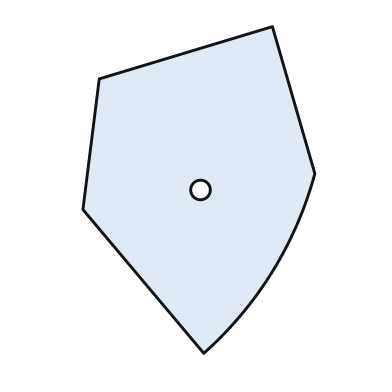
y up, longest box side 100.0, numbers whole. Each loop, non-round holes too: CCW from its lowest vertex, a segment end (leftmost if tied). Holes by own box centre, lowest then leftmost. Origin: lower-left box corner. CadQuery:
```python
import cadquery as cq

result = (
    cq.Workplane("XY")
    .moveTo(37.0, 0.0)
    .threePointArc((58.0, 25.0), (71.0, 55.0))
    .lineTo(58.0, 100.0)
    .lineTo(5.0, 84.0)
    .lineTo(0.0, 44.0)
    .close()
    .moveTo(36.0, 50.0)
    .circle(3.0)
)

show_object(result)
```